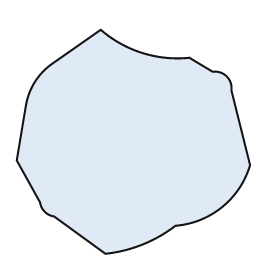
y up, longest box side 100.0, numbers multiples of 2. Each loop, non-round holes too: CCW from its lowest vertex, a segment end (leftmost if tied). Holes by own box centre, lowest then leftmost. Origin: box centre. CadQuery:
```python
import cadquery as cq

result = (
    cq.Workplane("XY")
    .moveTo(-12.0, -48.0)
    .threePointArc((4.0, -44.0), (18.0, -36.0))
    .threePointArc((38.0, -28.0), (50.0, -10.0))
    .lineTo(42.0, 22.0)
    .threePointArc((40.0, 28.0), (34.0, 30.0))
    .lineTo(24.0, 36.0)
    .threePointArc((4.0, 38.0), (-14.0, 48.0))
    .lineTo(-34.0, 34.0)
    .threePointArc((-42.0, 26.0), (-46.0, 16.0))
    .lineTo(-50.0, -8.0)
    .lineTo(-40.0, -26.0)
    .threePointArc((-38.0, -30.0), (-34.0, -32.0))
    .close()
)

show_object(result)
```